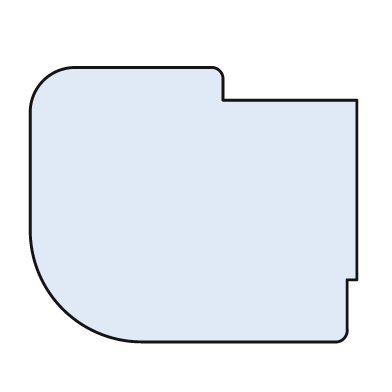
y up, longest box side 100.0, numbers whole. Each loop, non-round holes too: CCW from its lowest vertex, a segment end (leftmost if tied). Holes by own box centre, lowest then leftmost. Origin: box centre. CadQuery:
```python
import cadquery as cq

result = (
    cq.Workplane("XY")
    .moveTo(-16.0, -42.0)
    .lineTo(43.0, -42.0)
    .threePointArc((46.0, -41.0), (47.0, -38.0))
    .lineTo(47.0, -23.0)
    .lineTo(50.0, -23.0)
    .lineTo(50.0, 32.0)
    .lineTo(9.0, 32.0)
    .lineTo(9.0, 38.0)
    .threePointArc((8.0, 41.0), (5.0, 42.0))
    .lineTo(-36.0, 42.0)
    .threePointArc((-46.0, 38.0), (-50.0, 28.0))
    .lineTo(-50.0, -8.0)
    .threePointArc((-40.0, -32.0), (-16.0, -42.0))
    .close()
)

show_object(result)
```